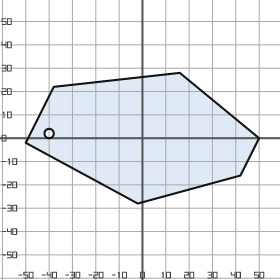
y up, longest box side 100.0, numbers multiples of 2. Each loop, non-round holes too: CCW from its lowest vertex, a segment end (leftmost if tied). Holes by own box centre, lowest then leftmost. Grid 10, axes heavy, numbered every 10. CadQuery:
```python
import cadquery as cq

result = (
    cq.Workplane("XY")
    .moveTo(-2.0, -28.0)
    .lineTo(42.0, -16.0)
    .lineTo(50.0, 0.0)
    .lineTo(16.0, 28.0)
    .lineTo(-38.0, 22.0)
    .lineTo(-50.0, -2.0)
    .close()
    .moveTo(-40.0, 2.0)
    .circle(2.0)
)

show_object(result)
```